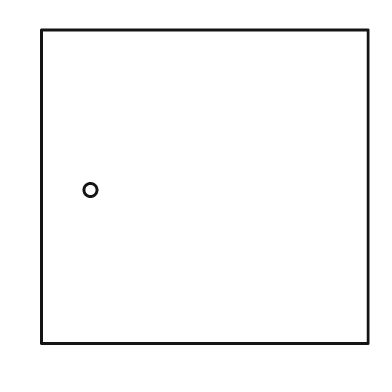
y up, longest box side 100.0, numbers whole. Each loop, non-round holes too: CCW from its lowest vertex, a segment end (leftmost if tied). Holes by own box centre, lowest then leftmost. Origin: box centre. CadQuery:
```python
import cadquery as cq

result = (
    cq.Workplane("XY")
    .moveTo(-50.0, -48.0)
    .lineTo(50.0, -48.0)
    .lineTo(50.0, 48.0)
    .lineTo(-50.0, 48.0)
    .close()
    .moveTo(-35.0, -1.0)
    .circle(2.0)
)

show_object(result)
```